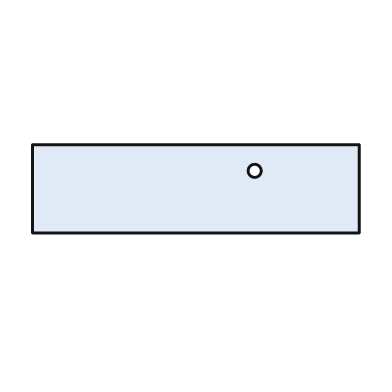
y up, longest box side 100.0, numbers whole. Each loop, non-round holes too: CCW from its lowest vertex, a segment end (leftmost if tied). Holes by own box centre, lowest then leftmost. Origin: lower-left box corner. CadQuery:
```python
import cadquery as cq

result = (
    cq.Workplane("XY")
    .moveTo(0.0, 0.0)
    .lineTo(100.0, 0.0)
    .lineTo(100.0, 27.0)
    .lineTo(0.0, 27.0)
    .close()
    .moveTo(68.0, 19.0)
    .circle(2.0)
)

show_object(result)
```